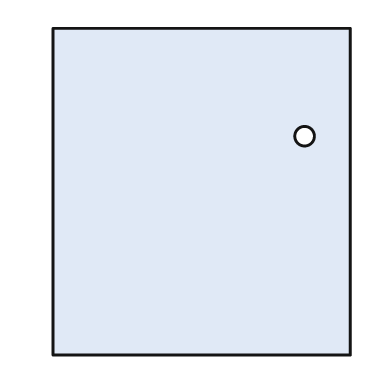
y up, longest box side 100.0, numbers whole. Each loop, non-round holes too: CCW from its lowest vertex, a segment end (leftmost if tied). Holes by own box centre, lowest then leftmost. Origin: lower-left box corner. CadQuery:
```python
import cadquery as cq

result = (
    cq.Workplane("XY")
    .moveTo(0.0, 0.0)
    .lineTo(91.0, 0.0)
    .lineTo(91.0, 100.0)
    .lineTo(0.0, 100.0)
    .close()
    .moveTo(77.0, 67.0)
    .circle(3.0)
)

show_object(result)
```